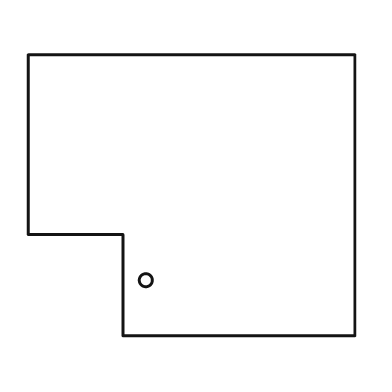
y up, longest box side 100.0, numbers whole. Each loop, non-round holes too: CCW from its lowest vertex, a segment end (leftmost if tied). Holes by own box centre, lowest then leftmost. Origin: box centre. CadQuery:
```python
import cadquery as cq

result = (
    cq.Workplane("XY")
    .moveTo(-21.0, -43.0)
    .lineTo(50.0, -43.0)
    .lineTo(50.0, 43.0)
    .lineTo(-50.0, 43.0)
    .lineTo(-50.0, -12.0)
    .lineTo(-21.0, -12.0)
    .close()
    .moveTo(-14.0, -26.0)
    .circle(2.0)
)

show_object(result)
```